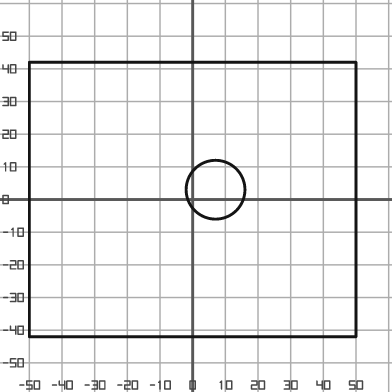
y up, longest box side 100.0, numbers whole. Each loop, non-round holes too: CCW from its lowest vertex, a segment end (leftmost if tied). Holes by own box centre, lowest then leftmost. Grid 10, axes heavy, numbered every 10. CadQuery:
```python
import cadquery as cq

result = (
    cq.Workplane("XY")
    .moveTo(-50.0, -42.0)
    .lineTo(50.0, -42.0)
    .lineTo(50.0, 42.0)
    .lineTo(-50.0, 42.0)
    .close()
    .moveTo(7.0, 3.0)
    .circle(9.0)
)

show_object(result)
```